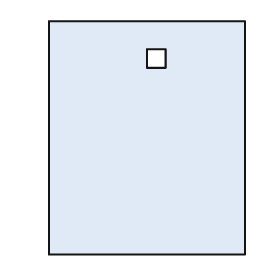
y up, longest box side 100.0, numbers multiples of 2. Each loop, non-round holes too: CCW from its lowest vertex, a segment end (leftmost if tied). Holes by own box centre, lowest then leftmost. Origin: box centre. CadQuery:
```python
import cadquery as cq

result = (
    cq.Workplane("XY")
    .moveTo(-42.0, -50.0)
    .lineTo(42.0, -50.0)
    .lineTo(42.0, 50.0)
    .lineTo(-42.0, 50.0)
    .close()
    .moveTo(0.0, 30.0)
    .lineTo(8.0, 30.0)
    .lineTo(8.0, 38.0)
    .lineTo(0.0, 38.0)
    .close()
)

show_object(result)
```